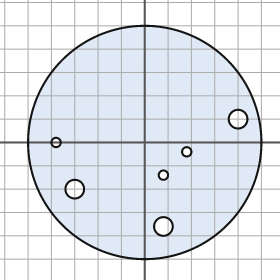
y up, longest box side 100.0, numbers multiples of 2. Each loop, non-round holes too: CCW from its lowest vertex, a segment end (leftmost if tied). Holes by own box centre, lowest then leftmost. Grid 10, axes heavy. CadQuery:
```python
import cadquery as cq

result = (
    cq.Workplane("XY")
    .moveTo(0.0, 0.0)
    .circle(50.0)
    .moveTo(8.0, -36.0)
    .circle(4.0)
    .moveTo(-30.0, -20.0)
    .circle(4.0)
    .moveTo(8.0, -14.0)
    .circle(2.0)
    .moveTo(18.0, -4.0)
    .circle(2.0)
    .moveTo(-38.0, 0.0)
    .circle(2.0)
    .moveTo(40.0, 10.0)
    .circle(4.0)
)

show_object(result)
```